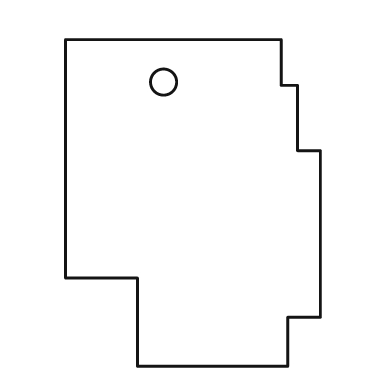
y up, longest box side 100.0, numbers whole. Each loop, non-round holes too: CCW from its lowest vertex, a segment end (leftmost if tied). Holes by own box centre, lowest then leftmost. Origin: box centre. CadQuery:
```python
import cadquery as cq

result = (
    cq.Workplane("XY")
    .moveTo(-17.0, -50.0)
    .lineTo(29.0, -50.0)
    .lineTo(29.0, -35.0)
    .lineTo(39.0, -35.0)
    .lineTo(39.0, 16.0)
    .lineTo(32.0, 16.0)
    .lineTo(32.0, 36.0)
    .lineTo(27.0, 36.0)
    .lineTo(27.0, 50.0)
    .lineTo(-39.0, 50.0)
    .lineTo(-39.0, -23.0)
    .lineTo(-17.0, -23.0)
    .close()
    .moveTo(-9.0, 37.0)
    .circle(4.0)
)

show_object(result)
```